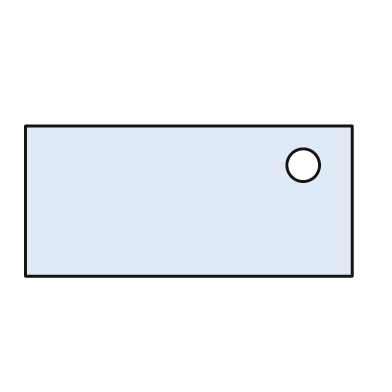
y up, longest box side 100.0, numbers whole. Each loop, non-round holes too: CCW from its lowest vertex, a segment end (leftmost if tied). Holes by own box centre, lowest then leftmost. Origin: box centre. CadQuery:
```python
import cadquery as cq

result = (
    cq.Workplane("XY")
    .moveTo(-50.0, -23.0)
    .lineTo(50.0, -23.0)
    .lineTo(50.0, 23.0)
    .lineTo(-50.0, 23.0)
    .close()
    .moveTo(35.0, 11.0)
    .circle(5.0)
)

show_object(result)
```